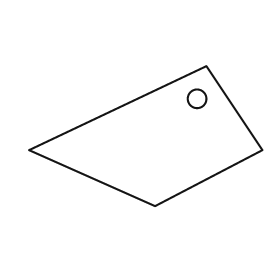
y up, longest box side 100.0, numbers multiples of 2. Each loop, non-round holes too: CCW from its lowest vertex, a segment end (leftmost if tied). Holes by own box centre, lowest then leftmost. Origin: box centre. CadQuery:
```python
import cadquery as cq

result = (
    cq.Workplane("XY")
    .moveTo(4.0, -30.0)
    .lineTo(50.0, -6.0)
    .lineTo(26.0, 30.0)
    .lineTo(-50.0, -6.0)
    .close()
    .moveTo(22.0, 16.0)
    .circle(4.0)
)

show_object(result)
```